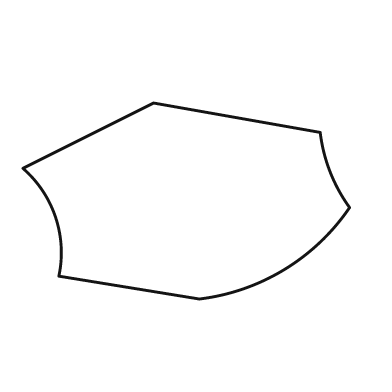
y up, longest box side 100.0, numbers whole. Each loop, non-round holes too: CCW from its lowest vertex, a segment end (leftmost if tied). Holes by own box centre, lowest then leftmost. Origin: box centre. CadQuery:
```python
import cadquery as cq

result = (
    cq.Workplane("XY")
    .moveTo(4.0, -30.0)
    .threePointArc((30.0, -21.0), (50.0, -2.0))
    .threePointArc((44.0, 9.0), (41.0, 21.0))
    .lineTo(-10.0, 30.0)
    .lineTo(-50.0, 10.0)
    .threePointArc((-40.0, -5.0), (-39.0, -23.0))
    .close()
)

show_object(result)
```